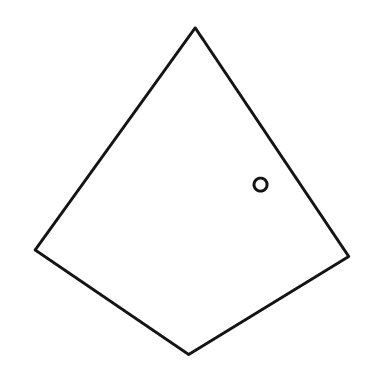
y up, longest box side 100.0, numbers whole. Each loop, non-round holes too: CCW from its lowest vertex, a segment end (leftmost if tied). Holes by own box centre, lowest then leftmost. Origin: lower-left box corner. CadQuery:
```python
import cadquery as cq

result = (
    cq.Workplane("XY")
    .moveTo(47.0, 0.0)
    .lineTo(96.0, 30.0)
    .lineTo(49.0, 100.0)
    .lineTo(0.0, 32.0)
    .close()
    .moveTo(69.0, 52.0)
    .circle(2.0)
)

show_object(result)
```